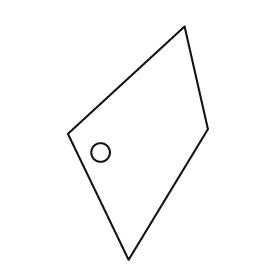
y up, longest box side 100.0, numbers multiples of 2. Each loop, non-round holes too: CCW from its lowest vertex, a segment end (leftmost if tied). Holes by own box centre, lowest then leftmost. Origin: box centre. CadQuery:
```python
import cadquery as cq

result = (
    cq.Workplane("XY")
    .moveTo(-4.0, -50.0)
    .lineTo(30.0, 6.0)
    .lineTo(20.0, 50.0)
    .lineTo(-30.0, 4.0)
    .close()
    .moveTo(-16.0, -4.0)
    .circle(4.0)
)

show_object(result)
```